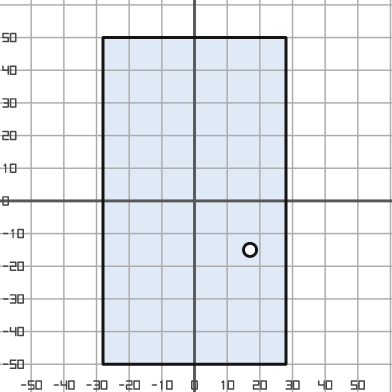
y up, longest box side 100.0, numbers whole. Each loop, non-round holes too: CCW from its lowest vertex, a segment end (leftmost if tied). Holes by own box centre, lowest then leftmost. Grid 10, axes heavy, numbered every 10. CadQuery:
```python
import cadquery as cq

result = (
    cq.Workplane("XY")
    .moveTo(-28.0, -50.0)
    .lineTo(28.0, -50.0)
    .lineTo(28.0, 50.0)
    .lineTo(-28.0, 50.0)
    .close()
    .moveTo(17.0, -15.0)
    .circle(2.0)
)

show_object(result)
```